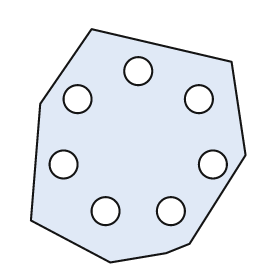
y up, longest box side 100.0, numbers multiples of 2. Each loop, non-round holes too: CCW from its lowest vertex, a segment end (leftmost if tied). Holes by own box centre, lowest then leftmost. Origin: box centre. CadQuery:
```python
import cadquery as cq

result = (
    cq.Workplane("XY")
    .moveTo(-12.0, -50.0)
    .lineTo(12.0, -46.0)
    .lineTo(22.0, -42.0)
    .lineTo(46.0, -4.0)
    .lineTo(40.0, 36.0)
    .lineTo(-20.0, 50.0)
    .lineTo(-42.0, 18.0)
    .lineTo(-46.0, -32.0)
    .close()
    .moveTo(-14.0, -28.0)
    .circle(6.0)
    .moveTo(14.0, -28.0)
    .circle(6.0)
    .moveTo(-32.0, -8.0)
    .circle(6.0)
    .moveTo(32.0, -8.0)
    .circle(6.0)
    .moveTo(-26.0, 20.0)
    .circle(6.0)
    .moveTo(26.0, 20.0)
    .circle(6.0)
    .moveTo(0.0, 32.0)
    .circle(6.0)
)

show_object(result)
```